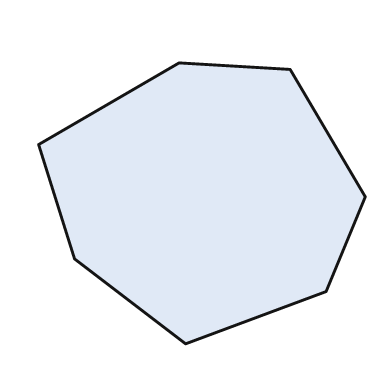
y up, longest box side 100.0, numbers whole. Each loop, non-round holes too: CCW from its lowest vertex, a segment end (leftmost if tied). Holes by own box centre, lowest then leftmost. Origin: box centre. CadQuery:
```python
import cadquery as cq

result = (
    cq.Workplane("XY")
    .moveTo(-5.0, -43.0)
    .lineTo(38.0, -27.0)
    .lineTo(50.0, 2.0)
    .lineTo(27.0, 41.0)
    .lineTo(-7.0, 43.0)
    .lineTo(-50.0, 18.0)
    .lineTo(-39.0, -17.0)
    .close()
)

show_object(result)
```